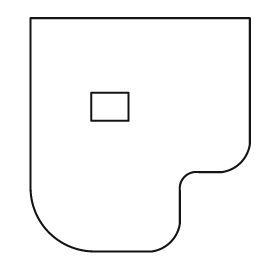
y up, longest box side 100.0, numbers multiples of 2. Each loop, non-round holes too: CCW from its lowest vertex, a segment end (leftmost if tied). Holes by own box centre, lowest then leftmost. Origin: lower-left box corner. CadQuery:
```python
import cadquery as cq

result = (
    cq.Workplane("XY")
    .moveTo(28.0, 0.0)
    .lineTo(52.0, 0.0)
    .threePointArc((60.0, 4.0), (64.0, 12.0))
    .lineTo(64.0, 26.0)
    .threePointArc((66.0, 32.0), (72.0, 34.0))
    .lineTo(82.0, 34.0)
    .threePointArc((90.0, 38.0), (94.0, 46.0))
    .lineTo(94.0, 100.0)
    .lineTo(0.0, 100.0)
    .lineTo(0.0, 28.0)
    .threePointArc((8.0, 8.0), (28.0, 0.0))
    .close()
    .moveTo(26.0, 56.0)
    .lineTo(42.0, 56.0)
    .lineTo(42.0, 68.0)
    .lineTo(26.0, 68.0)
    .close()
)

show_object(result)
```